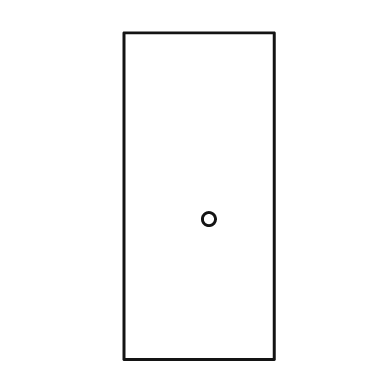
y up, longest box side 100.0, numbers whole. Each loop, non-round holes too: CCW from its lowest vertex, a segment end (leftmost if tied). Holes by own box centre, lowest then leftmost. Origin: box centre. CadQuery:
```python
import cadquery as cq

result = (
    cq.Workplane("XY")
    .moveTo(-23.0, -50.0)
    .lineTo(23.0, -50.0)
    .lineTo(23.0, 50.0)
    .lineTo(-23.0, 50.0)
    .close()
    .moveTo(3.0, -7.0)
    .circle(2.0)
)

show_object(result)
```